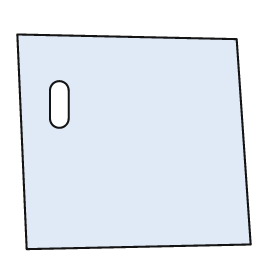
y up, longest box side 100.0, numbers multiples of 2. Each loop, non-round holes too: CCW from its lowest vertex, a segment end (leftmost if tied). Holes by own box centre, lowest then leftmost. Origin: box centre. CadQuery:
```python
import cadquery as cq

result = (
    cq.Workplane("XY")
    .moveTo(-46.0, -46.0)
    .lineTo(50.0, -44.0)
    .lineTo(44.0, 44.0)
    .lineTo(-50.0, 46.0)
    .close()
    .moveTo(-36.0, 10.0)
    .threePointArc((-32.0, 6.0), (-28.0, 10.0))
    .lineTo(-28.0, 22.0)
    .threePointArc((-32.0, 26.0), (-36.0, 22.0))
    .close()
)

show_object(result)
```